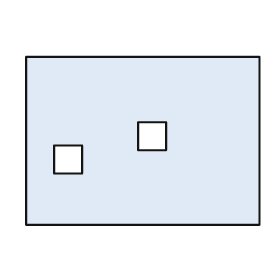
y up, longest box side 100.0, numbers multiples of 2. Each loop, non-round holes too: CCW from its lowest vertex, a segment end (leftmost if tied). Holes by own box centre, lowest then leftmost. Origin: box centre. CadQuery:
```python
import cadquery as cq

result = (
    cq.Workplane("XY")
    .moveTo(-50.0, -36.0)
    .lineTo(50.0, -36.0)
    .lineTo(50.0, 36.0)
    .lineTo(-50.0, 36.0)
    .close()
    .moveTo(-38.0, -14.0)
    .lineTo(-26.0, -14.0)
    .lineTo(-26.0, -2.0)
    .lineTo(-38.0, -2.0)
    .close()
    .moveTo(-2.0, -4.0)
    .lineTo(10.0, -4.0)
    .lineTo(10.0, 8.0)
    .lineTo(-2.0, 8.0)
    .close()
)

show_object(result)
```